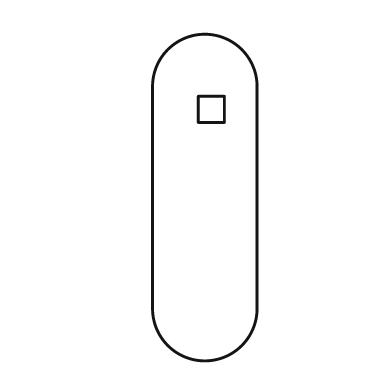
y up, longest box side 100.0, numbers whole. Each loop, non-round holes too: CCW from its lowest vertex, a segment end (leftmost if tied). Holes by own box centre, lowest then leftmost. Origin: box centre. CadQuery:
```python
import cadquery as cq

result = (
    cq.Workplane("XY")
    .moveTo(-16.0, -34.0)
    .threePointArc((0.0, -50.0), (16.0, -34.0))
    .lineTo(16.0, 34.0)
    .threePointArc((0.0, 50.0), (-16.0, 34.0))
    .close()
    .moveTo(-2.0, 23.0)
    .lineTo(6.0, 23.0)
    .lineTo(6.0, 31.0)
    .lineTo(-2.0, 31.0)
    .close()
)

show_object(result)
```